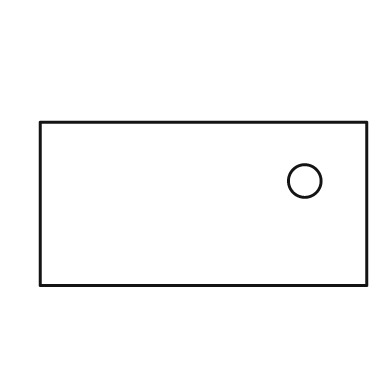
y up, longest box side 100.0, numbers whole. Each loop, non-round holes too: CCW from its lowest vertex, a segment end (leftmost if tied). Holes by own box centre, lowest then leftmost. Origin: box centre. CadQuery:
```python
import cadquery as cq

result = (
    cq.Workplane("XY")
    .moveTo(-50.0, -25.0)
    .lineTo(50.0, -25.0)
    .lineTo(50.0, 25.0)
    .lineTo(-50.0, 25.0)
    .close()
    .moveTo(31.0, 7.0)
    .circle(5.0)
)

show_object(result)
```